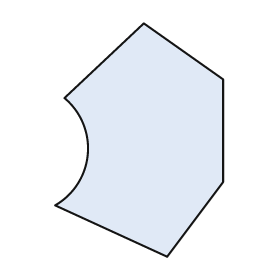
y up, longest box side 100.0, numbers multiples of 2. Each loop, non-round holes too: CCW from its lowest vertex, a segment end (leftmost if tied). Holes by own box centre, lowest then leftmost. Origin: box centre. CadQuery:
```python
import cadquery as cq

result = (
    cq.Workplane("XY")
    .moveTo(12.0, -50.0)
    .lineTo(36.0, -18.0)
    .lineTo(36.0, 26.0)
    .lineTo(2.0, 50.0)
    .lineTo(-32.0, 18.0)
    .threePointArc((-22.0, -6.0), (-36.0, -28.0))
    .close()
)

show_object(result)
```